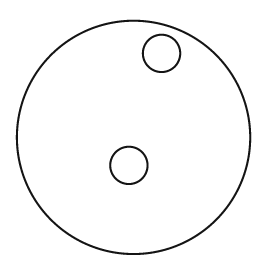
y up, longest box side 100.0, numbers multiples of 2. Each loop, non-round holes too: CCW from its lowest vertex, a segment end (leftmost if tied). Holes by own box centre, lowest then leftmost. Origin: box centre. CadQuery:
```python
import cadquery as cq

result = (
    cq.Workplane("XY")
    .moveTo(0.0, 0.0)
    .circle(50.0)
    .moveTo(-2.0, -12.0)
    .circle(8.0)
    .moveTo(12.0, 36.0)
    .circle(8.0)
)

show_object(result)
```